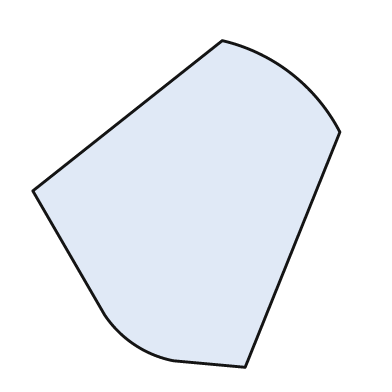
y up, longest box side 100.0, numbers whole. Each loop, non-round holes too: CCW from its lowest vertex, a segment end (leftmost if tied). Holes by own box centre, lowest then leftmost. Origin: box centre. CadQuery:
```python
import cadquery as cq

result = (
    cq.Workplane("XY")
    .moveTo(18.0, -50.0)
    .lineTo(47.0, 22.0)
    .threePointArc((32.0, 40.0), (11.0, 50.0))
    .lineTo(-47.0, 4.0)
    .lineTo(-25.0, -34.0)
    .threePointArc((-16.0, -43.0), (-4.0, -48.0))
    .close()
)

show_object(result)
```